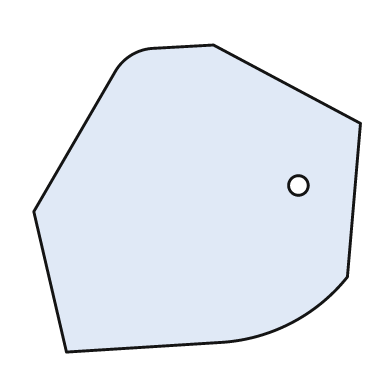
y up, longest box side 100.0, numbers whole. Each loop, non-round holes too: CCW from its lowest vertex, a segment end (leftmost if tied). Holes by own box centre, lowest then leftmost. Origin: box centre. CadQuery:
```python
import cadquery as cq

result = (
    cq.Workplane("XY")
    .moveTo(-40.0, -47.0)
    .lineTo(8.0, -44.0)
    .threePointArc((29.0, -38.0), (46.0, -24.0))
    .lineTo(50.0, 23.0)
    .lineTo(5.0, 47.0)
    .lineTo(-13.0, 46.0)
    .threePointArc((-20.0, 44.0), (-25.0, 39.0))
    .lineTo(-50.0, -4.0)
    .close()
    .moveTo(31.0, 4.0)
    .circle(3.0)
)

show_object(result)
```